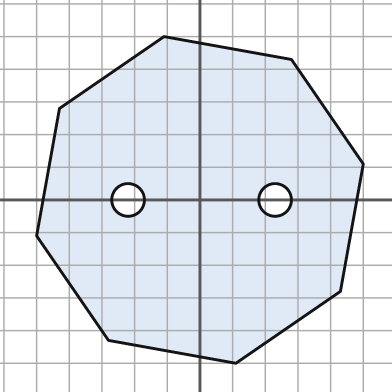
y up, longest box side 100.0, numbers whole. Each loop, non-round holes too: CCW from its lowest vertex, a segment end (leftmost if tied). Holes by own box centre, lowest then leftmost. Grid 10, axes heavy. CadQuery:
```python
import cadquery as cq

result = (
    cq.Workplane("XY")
    .moveTo(11.0, -50.0)
    .lineTo(43.0, -28.0)
    .lineTo(50.0, 11.0)
    .lineTo(28.0, 43.0)
    .lineTo(-11.0, 50.0)
    .lineTo(-43.0, 28.0)
    .lineTo(-50.0, -11.0)
    .lineTo(-28.0, -43.0)
    .close()
    .moveTo(-22.0, 0.0)
    .circle(5.0)
    .moveTo(23.0, 0.0)
    .circle(5.0)
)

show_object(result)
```